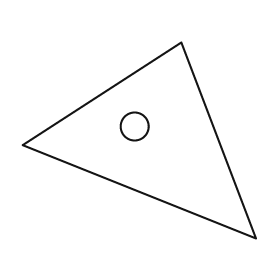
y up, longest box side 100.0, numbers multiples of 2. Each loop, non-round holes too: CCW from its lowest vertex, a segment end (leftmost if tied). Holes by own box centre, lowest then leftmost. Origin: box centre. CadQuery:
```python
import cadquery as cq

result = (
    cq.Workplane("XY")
    .moveTo(50.0, -42.0)
    .lineTo(18.0, 42.0)
    .lineTo(-50.0, -2.0)
    .close()
    .moveTo(-2.0, 6.0)
    .circle(6.0)
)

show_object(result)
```